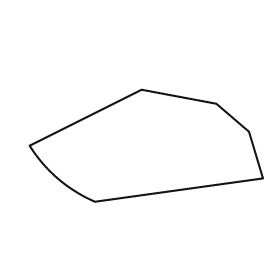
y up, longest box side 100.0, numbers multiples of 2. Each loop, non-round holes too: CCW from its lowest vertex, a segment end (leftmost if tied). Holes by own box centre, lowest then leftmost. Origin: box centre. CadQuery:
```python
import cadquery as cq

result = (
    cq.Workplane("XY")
    .moveTo(-22.0, -24.0)
    .lineTo(50.0, -14.0)
    .lineTo(44.0, 6.0)
    .lineTo(30.0, 18.0)
    .lineTo(-2.0, 24.0)
    .lineTo(-50.0, 0.0)
    .threePointArc((-38.0, -14.0), (-22.0, -24.0))
    .close()
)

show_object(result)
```